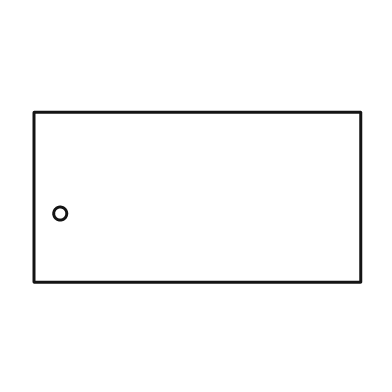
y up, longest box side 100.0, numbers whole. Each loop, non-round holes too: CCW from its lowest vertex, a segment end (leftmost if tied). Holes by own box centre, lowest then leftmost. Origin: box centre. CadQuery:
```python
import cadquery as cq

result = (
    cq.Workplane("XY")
    .moveTo(-50.0, -26.0)
    .lineTo(50.0, -26.0)
    .lineTo(50.0, 26.0)
    .lineTo(-50.0, 26.0)
    .close()
    .moveTo(-42.0, -5.0)
    .circle(2.0)
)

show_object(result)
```